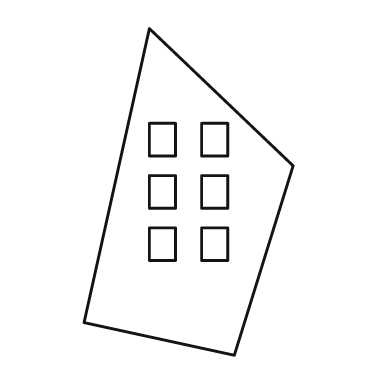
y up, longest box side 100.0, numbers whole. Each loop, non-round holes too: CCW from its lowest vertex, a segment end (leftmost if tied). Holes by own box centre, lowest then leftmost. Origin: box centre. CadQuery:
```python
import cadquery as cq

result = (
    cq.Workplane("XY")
    .moveTo(14.0, -50.0)
    .lineTo(32.0, 8.0)
    .lineTo(-12.0, 50.0)
    .lineTo(-32.0, -40.0)
    .close()
    .moveTo(-12.0, -21.0)
    .lineTo(-4.0, -21.0)
    .lineTo(-4.0, -11.0)
    .lineTo(-12.0, -11.0)
    .close()
    .moveTo(4.0, -21.0)
    .lineTo(12.0, -21.0)
    .lineTo(12.0, -11.0)
    .lineTo(4.0, -11.0)
    .close()
    .moveTo(-12.0, -5.0)
    .lineTo(-4.0, -5.0)
    .lineTo(-4.0, 5.0)
    .lineTo(-12.0, 5.0)
    .close()
    .moveTo(4.0, -5.0)
    .lineTo(12.0, -5.0)
    .lineTo(12.0, 5.0)
    .lineTo(4.0, 5.0)
    .close()
    .moveTo(-12.0, 11.0)
    .lineTo(-4.0, 11.0)
    .lineTo(-4.0, 21.0)
    .lineTo(-12.0, 21.0)
    .close()
    .moveTo(4.0, 11.0)
    .lineTo(12.0, 11.0)
    .lineTo(12.0, 21.0)
    .lineTo(4.0, 21.0)
    .close()
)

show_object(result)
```